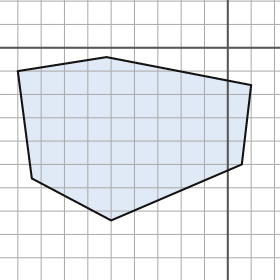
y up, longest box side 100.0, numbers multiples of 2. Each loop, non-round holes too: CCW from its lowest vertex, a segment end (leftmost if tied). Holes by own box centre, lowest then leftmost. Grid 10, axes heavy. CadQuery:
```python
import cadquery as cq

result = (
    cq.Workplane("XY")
    .moveTo(-50.0, -74.0)
    .lineTo(6.0, -50.0)
    .lineTo(10.0, -16.0)
    .lineTo(-52.0, -4.0)
    .lineTo(-90.0, -10.0)
    .lineTo(-84.0, -56.0)
    .close()
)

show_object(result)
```